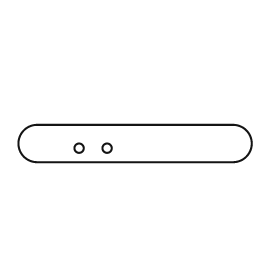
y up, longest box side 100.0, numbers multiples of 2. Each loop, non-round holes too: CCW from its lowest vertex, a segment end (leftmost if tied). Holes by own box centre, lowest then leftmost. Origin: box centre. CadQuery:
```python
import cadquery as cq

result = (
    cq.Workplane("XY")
    .moveTo(-42.0, -8.0)
    .lineTo(42.0, -8.0)
    .threePointArc((50.0, 0.0), (42.0, 8.0))
    .lineTo(-42.0, 8.0)
    .threePointArc((-50.0, 0.0), (-42.0, -8.0))
    .close()
    .moveTo(-24.0, -2.0)
    .circle(2.0)
    .moveTo(-12.0, -2.0)
    .circle(2.0)
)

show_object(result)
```